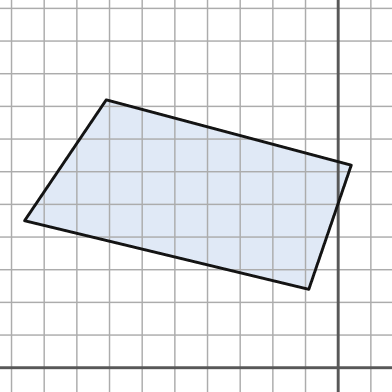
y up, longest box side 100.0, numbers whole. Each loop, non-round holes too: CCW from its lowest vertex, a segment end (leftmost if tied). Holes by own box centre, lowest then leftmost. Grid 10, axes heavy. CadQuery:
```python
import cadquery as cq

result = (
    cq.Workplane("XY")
    .moveTo(-9.0, 24.0)
    .lineTo(4.0, 62.0)
    .lineTo(-71.0, 82.0)
    .lineTo(-96.0, 45.0)
    .close()
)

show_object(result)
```